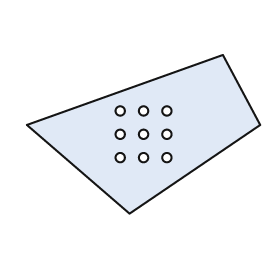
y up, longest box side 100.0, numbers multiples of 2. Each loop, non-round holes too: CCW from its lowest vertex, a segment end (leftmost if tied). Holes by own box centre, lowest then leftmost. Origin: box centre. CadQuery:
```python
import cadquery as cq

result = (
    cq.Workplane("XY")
    .moveTo(-6.0, -34.0)
    .lineTo(50.0, 4.0)
    .lineTo(34.0, 34.0)
    .lineTo(-50.0, 4.0)
    .close()
    .moveTo(-10.0, -10.0)
    .circle(2.0)
    .moveTo(0.0, -10.0)
    .circle(2.0)
    .moveTo(10.0, -10.0)
    .circle(2.0)
    .moveTo(-10.0, 0.0)
    .circle(2.0)
    .moveTo(0.0, 0.0)
    .circle(2.0)
    .moveTo(10.0, 0.0)
    .circle(2.0)
    .moveTo(-10.0, 10.0)
    .circle(2.0)
    .moveTo(0.0, 10.0)
    .circle(2.0)
    .moveTo(10.0, 10.0)
    .circle(2.0)
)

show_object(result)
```